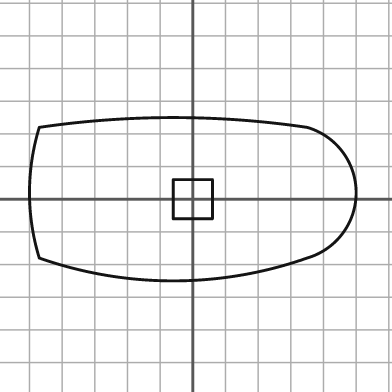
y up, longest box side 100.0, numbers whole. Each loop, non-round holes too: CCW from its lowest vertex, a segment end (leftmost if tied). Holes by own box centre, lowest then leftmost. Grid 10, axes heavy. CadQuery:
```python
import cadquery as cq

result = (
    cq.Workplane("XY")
    .moveTo(-47.0, -18.0)
    .threePointArc((-6.0, -25.0), (35.0, -18.0))
    .threePointArc((50.0, 2.0), (35.0, 22.0))
    .threePointArc((-6.0, 25.0), (-47.0, 22.0))
    .threePointArc((-50.0, 2.0), (-47.0, -18.0))
    .close()
    .moveTo(-6.0, -6.0)
    .lineTo(6.0, -6.0)
    .lineTo(6.0, 6.0)
    .lineTo(-6.0, 6.0)
    .close()
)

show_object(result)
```